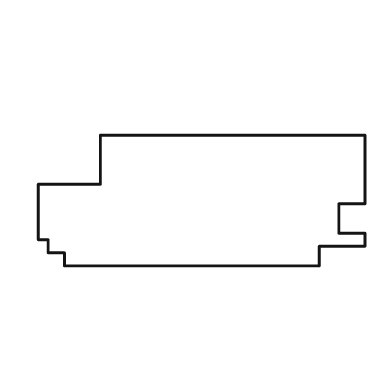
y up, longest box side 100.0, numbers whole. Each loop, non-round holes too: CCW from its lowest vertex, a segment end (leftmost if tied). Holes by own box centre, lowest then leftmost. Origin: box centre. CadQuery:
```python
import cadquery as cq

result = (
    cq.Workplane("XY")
    .moveTo(-42.0, -20.0)
    .lineTo(36.0, -20.0)
    .lineTo(36.0, -14.0)
    .lineTo(50.0, -14.0)
    .lineTo(50.0, -10.0)
    .lineTo(42.0, -10.0)
    .lineTo(42.0, -1.0)
    .lineTo(50.0, -1.0)
    .lineTo(50.0, 20.0)
    .lineTo(-31.0, 20.0)
    .lineTo(-31.0, 5.0)
    .lineTo(-50.0, 5.0)
    .lineTo(-50.0, -12.0)
    .lineTo(-47.0, -12.0)
    .lineTo(-47.0, -16.0)
    .lineTo(-42.0, -16.0)
    .close()
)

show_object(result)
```